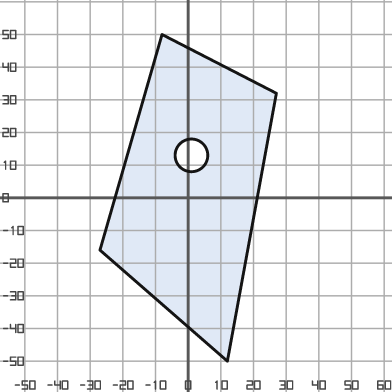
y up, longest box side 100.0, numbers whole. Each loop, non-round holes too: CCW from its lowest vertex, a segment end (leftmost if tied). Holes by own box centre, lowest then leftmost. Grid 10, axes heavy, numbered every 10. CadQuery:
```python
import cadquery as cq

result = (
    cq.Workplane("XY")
    .moveTo(12.0, -50.0)
    .lineTo(27.0, 32.0)
    .lineTo(-8.0, 50.0)
    .lineTo(-27.0, -16.0)
    .close()
    .moveTo(1.0, 13.0)
    .circle(5.0)
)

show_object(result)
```